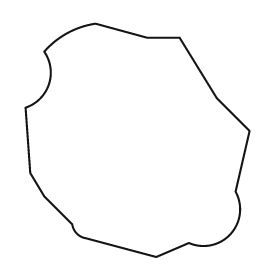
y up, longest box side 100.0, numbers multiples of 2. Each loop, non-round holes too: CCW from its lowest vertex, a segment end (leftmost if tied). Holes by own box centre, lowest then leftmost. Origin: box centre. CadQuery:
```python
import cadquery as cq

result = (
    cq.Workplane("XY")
    .moveTo(8.0, -50.0)
    .lineTo(22.0, -44.0)
    .threePointArc((40.0, -40.0), (42.0, -22.0))
    .lineTo(48.0, 4.0)
    .lineTo(34.0, 18.0)
    .lineTo(18.0, 44.0)
    .lineTo(4.0, 44.0)
    .lineTo(-18.0, 50.0)
    .threePointArc((-30.0, 46.0), (-40.0, 38.0))
    .threePointArc((-38.0, 24.0), (-48.0, 14.0))
    .lineTo(-46.0, -14.0)
    .lineTo(-40.0, -24.0)
    .lineTo(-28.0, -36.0)
    .threePointArc((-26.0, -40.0), (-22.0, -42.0))
    .close()
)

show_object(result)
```